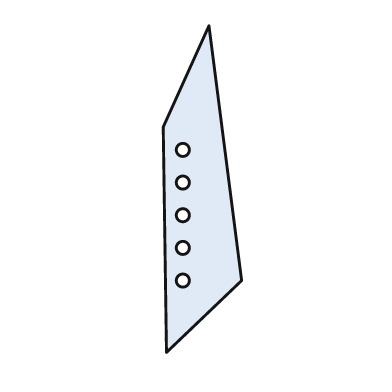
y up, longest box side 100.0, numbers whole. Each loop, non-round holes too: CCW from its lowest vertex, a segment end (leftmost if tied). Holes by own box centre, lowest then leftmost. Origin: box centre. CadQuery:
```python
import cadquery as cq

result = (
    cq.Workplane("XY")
    .moveTo(-11.0, -50.0)
    .lineTo(12.0, -28.0)
    .lineTo(2.0, 50.0)
    .lineTo(-12.0, 19.0)
    .close()
    .moveTo(-6.0, -28.0)
    .circle(2.0)
    .moveTo(-6.0, -18.0)
    .circle(2.0)
    .moveTo(-6.0, -8.0)
    .circle(2.0)
    .moveTo(-6.0, 2.0)
    .circle(2.0)
    .moveTo(-6.0, 12.0)
    .circle(2.0)
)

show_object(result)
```